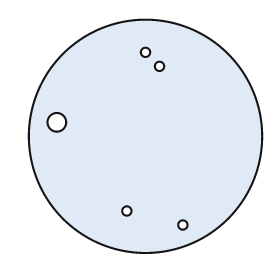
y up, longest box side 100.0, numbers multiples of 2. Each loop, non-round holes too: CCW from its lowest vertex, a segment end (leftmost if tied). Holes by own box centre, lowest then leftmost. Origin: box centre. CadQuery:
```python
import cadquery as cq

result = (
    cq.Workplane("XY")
    .moveTo(0.0, 0.0)
    .circle(50.0)
    .moveTo(16.0, -38.0)
    .circle(2.0)
    .moveTo(-8.0, -32.0)
    .circle(2.0)
    .moveTo(-38.0, 6.0)
    .circle(4.0)
    .moveTo(6.0, 30.0)
    .circle(2.0)
    .moveTo(0.0, 36.0)
    .circle(2.0)
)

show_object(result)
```